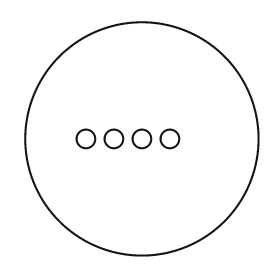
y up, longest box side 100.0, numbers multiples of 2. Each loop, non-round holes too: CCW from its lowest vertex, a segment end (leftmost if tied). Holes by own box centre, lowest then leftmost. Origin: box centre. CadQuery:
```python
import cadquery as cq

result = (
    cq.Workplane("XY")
    .moveTo(0.0, 0.0)
    .circle(50.0)
    .moveTo(-24.0, 0.0)
    .circle(4.0)
    .moveTo(-12.0, 0.0)
    .circle(4.0)
    .moveTo(0.0, 0.0)
    .circle(4.0)
    .moveTo(12.0, 0.0)
    .circle(4.0)
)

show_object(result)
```